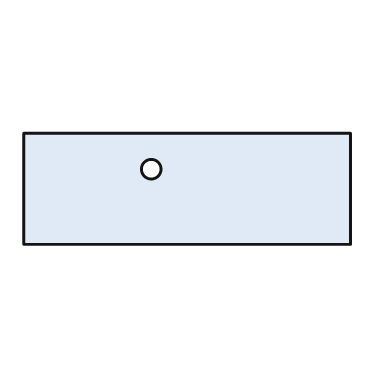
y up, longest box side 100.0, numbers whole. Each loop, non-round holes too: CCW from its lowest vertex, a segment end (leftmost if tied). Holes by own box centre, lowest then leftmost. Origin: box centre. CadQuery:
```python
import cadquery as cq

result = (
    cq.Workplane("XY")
    .moveTo(-50.0, -17.0)
    .lineTo(50.0, -17.0)
    .lineTo(50.0, 17.0)
    .lineTo(-50.0, 17.0)
    .close()
    .moveTo(-11.0, 6.0)
    .circle(3.0)
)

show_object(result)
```